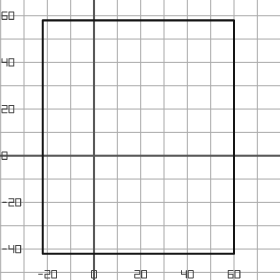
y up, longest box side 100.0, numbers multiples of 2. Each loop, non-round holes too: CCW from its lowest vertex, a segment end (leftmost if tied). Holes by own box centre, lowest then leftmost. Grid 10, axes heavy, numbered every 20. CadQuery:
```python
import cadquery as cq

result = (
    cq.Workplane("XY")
    .moveTo(-22.0, -42.0)
    .lineTo(60.0, -42.0)
    .lineTo(60.0, 58.0)
    .lineTo(-22.0, 58.0)
    .close()
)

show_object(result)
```